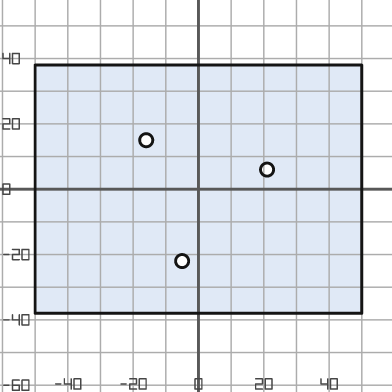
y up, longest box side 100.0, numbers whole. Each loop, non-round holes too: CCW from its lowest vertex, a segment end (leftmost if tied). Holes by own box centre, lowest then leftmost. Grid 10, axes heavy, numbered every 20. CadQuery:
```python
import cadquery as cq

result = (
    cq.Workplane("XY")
    .moveTo(-50.0, -38.0)
    .lineTo(50.0, -38.0)
    .lineTo(50.0, 38.0)
    .lineTo(-50.0, 38.0)
    .close()
    .moveTo(-5.0, -22.0)
    .circle(2.0)
    .moveTo(21.0, 6.0)
    .circle(2.0)
    .moveTo(-16.0, 15.0)
    .circle(2.0)
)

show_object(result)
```